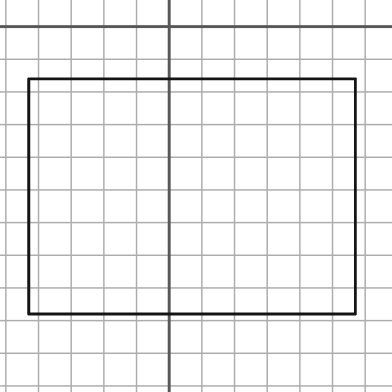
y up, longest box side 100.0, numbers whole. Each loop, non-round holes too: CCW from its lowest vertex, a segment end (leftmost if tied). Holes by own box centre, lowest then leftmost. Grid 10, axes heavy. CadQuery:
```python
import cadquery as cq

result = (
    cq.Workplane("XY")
    .moveTo(-43.0, -88.0)
    .lineTo(57.0, -88.0)
    .lineTo(57.0, -16.0)
    .lineTo(-43.0, -16.0)
    .close()
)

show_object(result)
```